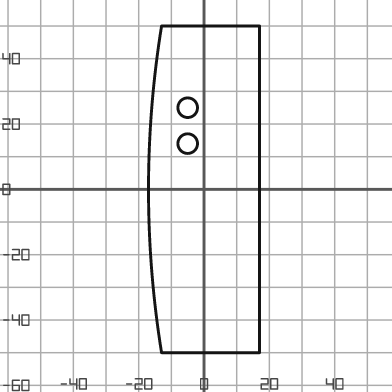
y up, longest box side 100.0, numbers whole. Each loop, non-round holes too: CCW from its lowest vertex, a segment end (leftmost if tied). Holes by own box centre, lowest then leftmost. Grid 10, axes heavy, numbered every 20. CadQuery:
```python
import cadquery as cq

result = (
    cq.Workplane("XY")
    .moveTo(-13.0, -50.0)
    .lineTo(17.0, -50.0)
    .lineTo(17.0, 50.0)
    .lineTo(-13.0, 50.0)
    .threePointArc((-17.0, 0.0), (-13.0, -50.0))
    .close()
    .moveTo(-5.0, 14.0)
    .circle(3.0)
    .moveTo(-5.0, 25.0)
    .circle(3.0)
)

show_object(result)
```